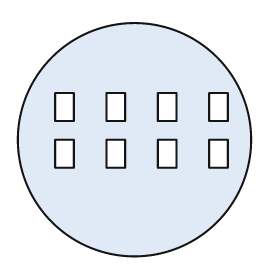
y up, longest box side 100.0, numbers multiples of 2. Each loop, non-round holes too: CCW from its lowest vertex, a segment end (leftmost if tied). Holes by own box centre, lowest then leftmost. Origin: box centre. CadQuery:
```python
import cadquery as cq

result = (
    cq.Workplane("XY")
    .moveTo(0.0, 0.0)
    .circle(50.0)
    .moveTo(-34.0, -12.0)
    .lineTo(-26.0, -12.0)
    .lineTo(-26.0, 0.0)
    .lineTo(-34.0, 0.0)
    .close()
    .moveTo(-12.0, -12.0)
    .lineTo(-4.0, -12.0)
    .lineTo(-4.0, 0.0)
    .lineTo(-12.0, 0.0)
    .close()
    .moveTo(10.0, -12.0)
    .lineTo(18.0, -12.0)
    .lineTo(18.0, 0.0)
    .lineTo(10.0, 0.0)
    .close()
    .moveTo(32.0, -12.0)
    .lineTo(40.0, -12.0)
    .lineTo(40.0, 0.0)
    .lineTo(32.0, 0.0)
    .close()
    .moveTo(-34.0, 8.0)
    .lineTo(-26.0, 8.0)
    .lineTo(-26.0, 20.0)
    .lineTo(-34.0, 20.0)
    .close()
    .moveTo(-12.0, 8.0)
    .lineTo(-4.0, 8.0)
    .lineTo(-4.0, 20.0)
    .lineTo(-12.0, 20.0)
    .close()
    .moveTo(10.0, 8.0)
    .lineTo(18.0, 8.0)
    .lineTo(18.0, 20.0)
    .lineTo(10.0, 20.0)
    .close()
    .moveTo(32.0, 8.0)
    .lineTo(40.0, 8.0)
    .lineTo(40.0, 20.0)
    .lineTo(32.0, 20.0)
    .close()
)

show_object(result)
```